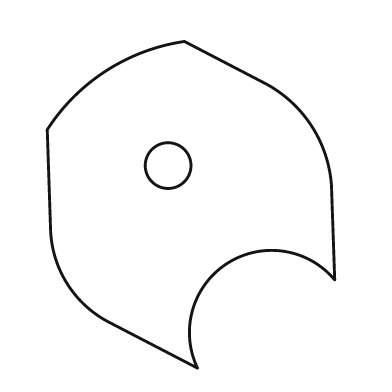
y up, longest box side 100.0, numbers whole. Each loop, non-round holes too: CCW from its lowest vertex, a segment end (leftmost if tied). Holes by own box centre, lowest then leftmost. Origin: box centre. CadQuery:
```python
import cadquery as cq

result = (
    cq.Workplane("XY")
    .moveTo(2.0, -50.0)
    .threePointArc((11.0, -18.0), (44.0, -23.0))
    .lineTo(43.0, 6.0)
    .threePointArc((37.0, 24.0), (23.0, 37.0))
    .lineTo(-2.0, 50.0)
    .threePointArc((-26.0, 41.0), (-44.0, 23.0))
    .lineTo(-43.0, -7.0)
    .threePointArc((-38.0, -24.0), (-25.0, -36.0))
    .close()
    .moveTo(-7.0, 12.0)
    .circle(7.0)
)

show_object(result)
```